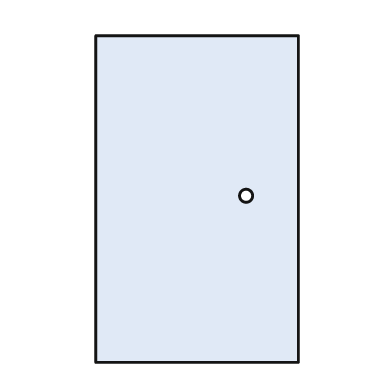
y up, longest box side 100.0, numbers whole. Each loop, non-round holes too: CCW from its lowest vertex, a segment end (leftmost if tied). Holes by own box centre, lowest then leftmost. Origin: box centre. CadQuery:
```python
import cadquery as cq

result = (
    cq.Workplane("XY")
    .moveTo(-31.0, -50.0)
    .lineTo(31.0, -50.0)
    .lineTo(31.0, 50.0)
    .lineTo(-31.0, 50.0)
    .close()
    .moveTo(15.0, 1.0)
    .circle(2.0)
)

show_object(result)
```